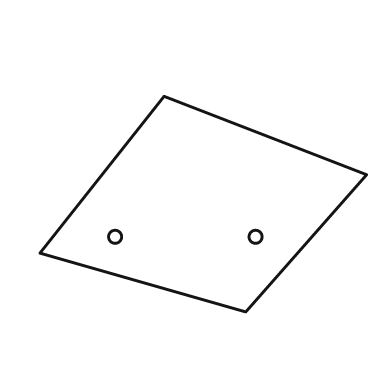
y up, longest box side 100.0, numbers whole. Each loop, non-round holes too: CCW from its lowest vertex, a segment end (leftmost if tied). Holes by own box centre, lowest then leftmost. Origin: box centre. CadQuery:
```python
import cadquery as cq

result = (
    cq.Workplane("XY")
    .moveTo(13.0, -33.0)
    .lineTo(50.0, 9.0)
    .lineTo(-12.0, 33.0)
    .lineTo(-50.0, -15.0)
    .close()
    .moveTo(-27.0, -10.0)
    .circle(2.0)
    .moveTo(16.0, -10.0)
    .circle(2.0)
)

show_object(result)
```